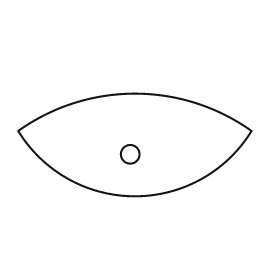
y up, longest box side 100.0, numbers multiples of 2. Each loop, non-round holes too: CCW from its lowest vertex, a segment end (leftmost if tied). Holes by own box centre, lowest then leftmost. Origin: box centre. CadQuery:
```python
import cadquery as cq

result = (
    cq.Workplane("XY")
    .moveTo(-50.0, 6.0)
    .threePointArc((0.0, -22.0), (50.0, 6.0))
    .threePointArc((0.0, 22.0), (-50.0, 6.0))
    .close()
    .moveTo(-2.0, -4.0)
    .circle(4.0)
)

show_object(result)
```